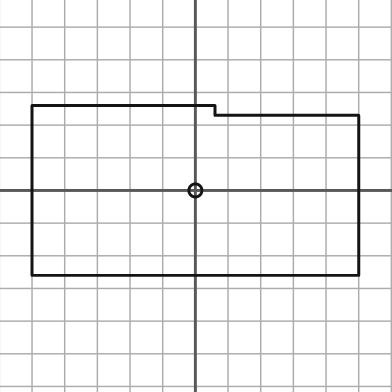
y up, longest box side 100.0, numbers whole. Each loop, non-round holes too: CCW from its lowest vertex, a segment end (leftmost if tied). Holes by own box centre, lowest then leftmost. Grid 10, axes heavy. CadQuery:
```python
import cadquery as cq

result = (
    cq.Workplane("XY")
    .moveTo(-50.0, -26.0)
    .lineTo(50.0, -26.0)
    .lineTo(50.0, 23.0)
    .lineTo(6.0, 23.0)
    .lineTo(6.0, 26.0)
    .lineTo(-50.0, 26.0)
    .close()
    .moveTo(0.0, 0.0)
    .circle(2.0)
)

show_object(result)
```